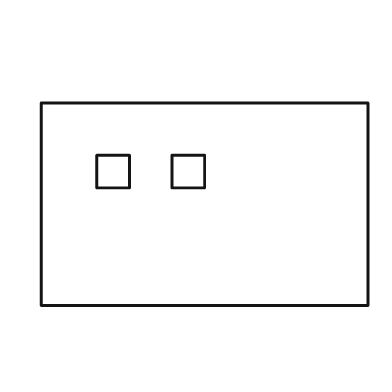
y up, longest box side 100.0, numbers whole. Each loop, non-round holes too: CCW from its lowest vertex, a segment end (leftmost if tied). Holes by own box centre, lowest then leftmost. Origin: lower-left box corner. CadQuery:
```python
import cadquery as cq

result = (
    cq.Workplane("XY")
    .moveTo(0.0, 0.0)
    .lineTo(100.0, 0.0)
    .lineTo(100.0, 62.0)
    .lineTo(0.0, 62.0)
    .close()
    .moveTo(17.0, 36.0)
    .lineTo(27.0, 36.0)
    .lineTo(27.0, 46.0)
    .lineTo(17.0, 46.0)
    .close()
    .moveTo(40.0, 36.0)
    .lineTo(50.0, 36.0)
    .lineTo(50.0, 46.0)
    .lineTo(40.0, 46.0)
    .close()
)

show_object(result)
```